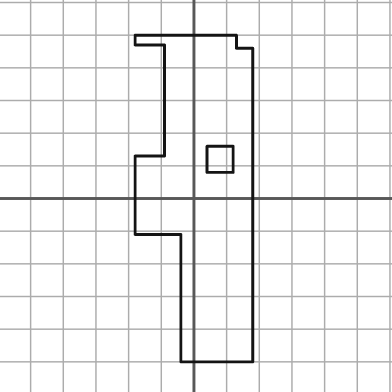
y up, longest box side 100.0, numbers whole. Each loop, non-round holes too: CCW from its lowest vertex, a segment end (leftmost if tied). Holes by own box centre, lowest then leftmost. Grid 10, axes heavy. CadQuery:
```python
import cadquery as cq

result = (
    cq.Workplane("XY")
    .moveTo(-4.0, -50.0)
    .lineTo(18.0, -50.0)
    .lineTo(18.0, 46.0)
    .lineTo(13.0, 46.0)
    .lineTo(13.0, 50.0)
    .lineTo(-18.0, 50.0)
    .lineTo(-18.0, 47.0)
    .lineTo(-9.0, 47.0)
    .lineTo(-9.0, 13.0)
    .lineTo(-18.0, 13.0)
    .lineTo(-18.0, -11.0)
    .lineTo(-4.0, -11.0)
    .close()
    .moveTo(4.0, 8.0)
    .lineTo(12.0, 8.0)
    .lineTo(12.0, 16.0)
    .lineTo(4.0, 16.0)
    .close()
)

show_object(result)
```